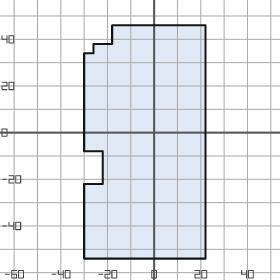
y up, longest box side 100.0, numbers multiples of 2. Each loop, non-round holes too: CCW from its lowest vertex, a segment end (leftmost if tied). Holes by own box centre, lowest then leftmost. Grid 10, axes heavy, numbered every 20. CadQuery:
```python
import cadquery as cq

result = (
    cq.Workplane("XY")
    .moveTo(-30.0, -54.0)
    .lineTo(22.0, -54.0)
    .lineTo(22.0, 46.0)
    .lineTo(-18.0, 46.0)
    .lineTo(-18.0, 38.0)
    .lineTo(-26.0, 38.0)
    .lineTo(-26.0, 34.0)
    .lineTo(-30.0, 34.0)
    .lineTo(-30.0, -8.0)
    .lineTo(-22.0, -8.0)
    .lineTo(-22.0, -22.0)
    .lineTo(-30.0, -22.0)
    .close()
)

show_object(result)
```